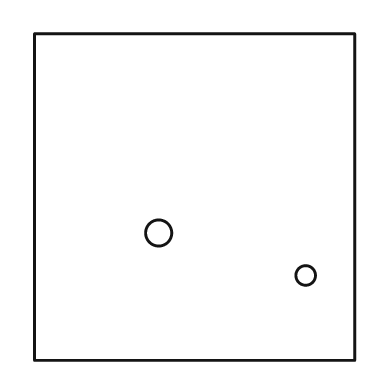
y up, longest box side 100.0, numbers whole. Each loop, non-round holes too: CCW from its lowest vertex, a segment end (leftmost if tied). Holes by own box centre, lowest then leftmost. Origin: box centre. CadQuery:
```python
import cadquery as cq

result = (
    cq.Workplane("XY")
    .moveTo(-49.0, -50.0)
    .lineTo(49.0, -50.0)
    .lineTo(49.0, 50.0)
    .lineTo(-49.0, 50.0)
    .close()
    .moveTo(34.0, -24.0)
    .circle(3.0)
    .moveTo(-11.0, -11.0)
    .circle(4.0)
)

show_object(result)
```